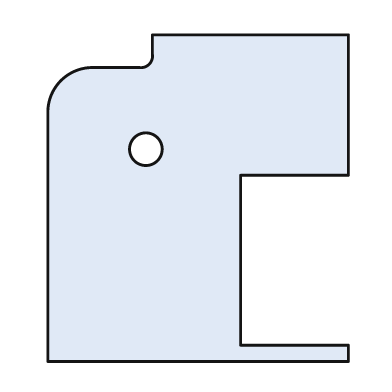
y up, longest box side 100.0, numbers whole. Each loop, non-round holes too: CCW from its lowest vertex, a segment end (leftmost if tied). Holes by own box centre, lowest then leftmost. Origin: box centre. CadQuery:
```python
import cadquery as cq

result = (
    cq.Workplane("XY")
    .moveTo(-46.0, -50.0)
    .lineTo(46.0, -50.0)
    .lineTo(46.0, -45.0)
    .lineTo(13.0, -45.0)
    .lineTo(13.0, 7.0)
    .lineTo(46.0, 7.0)
    .lineTo(46.0, 50.0)
    .lineTo(-14.0, 50.0)
    .lineTo(-14.0, 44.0)
    .threePointArc((-15.0, 41.0), (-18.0, 40.0))
    .lineTo(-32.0, 40.0)
    .threePointArc((-42.0, 36.0), (-46.0, 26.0))
    .close()
    .moveTo(-16.0, 15.0)
    .circle(5.0)
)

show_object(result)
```